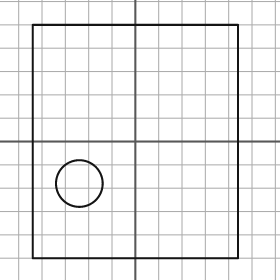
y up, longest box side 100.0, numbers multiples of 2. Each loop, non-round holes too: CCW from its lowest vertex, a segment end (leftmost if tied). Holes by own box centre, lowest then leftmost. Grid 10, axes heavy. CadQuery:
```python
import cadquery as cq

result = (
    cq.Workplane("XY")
    .moveTo(-44.0, -50.0)
    .lineTo(44.0, -50.0)
    .lineTo(44.0, 50.0)
    .lineTo(-44.0, 50.0)
    .close()
    .moveTo(-24.0, -18.0)
    .circle(10.0)
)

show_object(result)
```